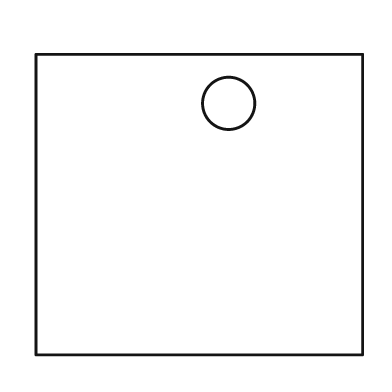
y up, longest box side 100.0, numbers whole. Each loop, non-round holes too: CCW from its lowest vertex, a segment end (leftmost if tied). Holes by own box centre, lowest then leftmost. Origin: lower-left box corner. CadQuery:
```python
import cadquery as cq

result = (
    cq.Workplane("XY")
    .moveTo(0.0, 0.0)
    .lineTo(100.0, 0.0)
    .lineTo(100.0, 92.0)
    .lineTo(0.0, 92.0)
    .close()
    .moveTo(59.0, 77.0)
    .circle(8.0)
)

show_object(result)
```